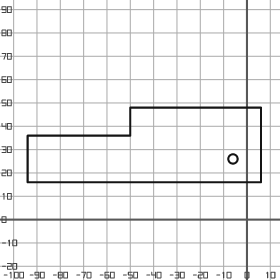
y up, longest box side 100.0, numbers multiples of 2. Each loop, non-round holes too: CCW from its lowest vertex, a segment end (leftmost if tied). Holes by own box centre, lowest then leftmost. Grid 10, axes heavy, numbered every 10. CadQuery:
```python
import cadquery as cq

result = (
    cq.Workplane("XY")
    .moveTo(-94.0, 16.0)
    .lineTo(6.0, 16.0)
    .lineTo(6.0, 48.0)
    .lineTo(-50.0, 48.0)
    .lineTo(-50.0, 36.0)
    .lineTo(-94.0, 36.0)
    .close()
    .moveTo(-6.0, 26.0)
    .circle(2.0)
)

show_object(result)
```